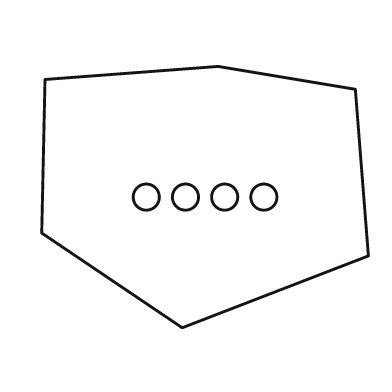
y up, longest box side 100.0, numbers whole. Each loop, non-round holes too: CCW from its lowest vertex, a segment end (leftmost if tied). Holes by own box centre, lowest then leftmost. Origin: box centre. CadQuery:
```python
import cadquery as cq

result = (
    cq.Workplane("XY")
    .moveTo(-7.0, -40.0)
    .lineTo(50.0, -18.0)
    .lineTo(46.0, 33.0)
    .lineTo(4.0, 40.0)
    .lineTo(-49.0, 36.0)
    .lineTo(-50.0, -11.0)
    .close()
    .moveTo(-18.0, 0.0)
    .circle(4.0)
    .moveTo(-6.0, 0.0)
    .circle(4.0)
    .moveTo(6.0, 0.0)
    .circle(4.0)
    .moveTo(18.0, 0.0)
    .circle(4.0)
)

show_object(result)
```